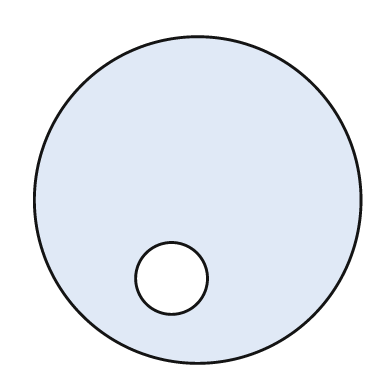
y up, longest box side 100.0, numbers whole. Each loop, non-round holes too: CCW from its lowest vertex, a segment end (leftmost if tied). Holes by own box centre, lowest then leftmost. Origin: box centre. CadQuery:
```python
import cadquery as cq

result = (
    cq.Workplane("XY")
    .moveTo(0.0, 0.0)
    .circle(50.0)
    .moveTo(-8.0, -24.0)
    .circle(11.0)
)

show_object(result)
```